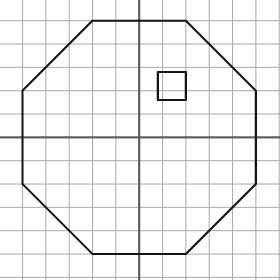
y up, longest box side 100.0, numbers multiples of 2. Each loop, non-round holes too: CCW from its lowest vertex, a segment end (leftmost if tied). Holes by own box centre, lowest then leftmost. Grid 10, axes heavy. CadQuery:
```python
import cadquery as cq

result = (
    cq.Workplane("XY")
    .moveTo(-20.0, -50.0)
    .lineTo(20.0, -50.0)
    .lineTo(50.0, -20.0)
    .lineTo(50.0, 20.0)
    .lineTo(20.0, 50.0)
    .lineTo(-20.0, 50.0)
    .lineTo(-50.0, 20.0)
    .lineTo(-50.0, -20.0)
    .close()
    .moveTo(8.0, 16.0)
    .lineTo(20.0, 16.0)
    .lineTo(20.0, 28.0)
    .lineTo(8.0, 28.0)
    .close()
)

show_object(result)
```